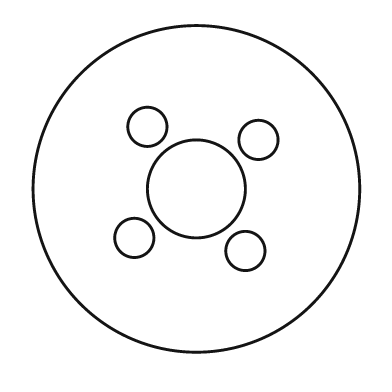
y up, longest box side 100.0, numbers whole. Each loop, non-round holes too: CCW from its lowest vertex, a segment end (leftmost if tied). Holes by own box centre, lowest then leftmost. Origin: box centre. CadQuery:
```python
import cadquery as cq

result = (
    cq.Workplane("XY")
    .moveTo(0.0, 0.0)
    .circle(50.0)
    .moveTo(15.0, -19.0)
    .circle(6.0)
    .moveTo(-19.0, -15.0)
    .circle(6.0)
    .moveTo(0.0, 0.0)
    .circle(15.0)
    .moveTo(19.0, 15.0)
    .circle(6.0)
    .moveTo(-15.0, 19.0)
    .circle(6.0)
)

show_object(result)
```